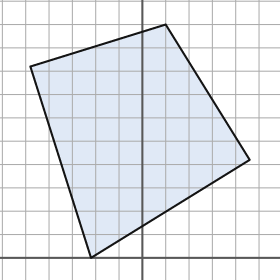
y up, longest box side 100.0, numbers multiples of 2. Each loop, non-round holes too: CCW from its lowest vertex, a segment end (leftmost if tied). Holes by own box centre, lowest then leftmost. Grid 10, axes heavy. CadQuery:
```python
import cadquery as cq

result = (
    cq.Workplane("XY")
    .moveTo(-22.0, 0.0)
    .lineTo(46.0, 42.0)
    .lineTo(10.0, 100.0)
    .lineTo(-48.0, 82.0)
    .close()
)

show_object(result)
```